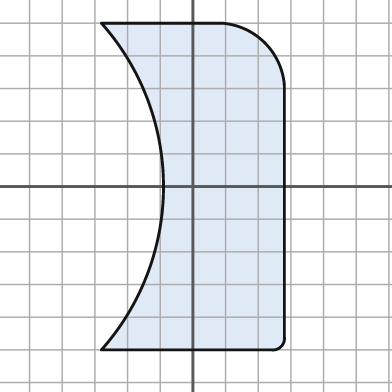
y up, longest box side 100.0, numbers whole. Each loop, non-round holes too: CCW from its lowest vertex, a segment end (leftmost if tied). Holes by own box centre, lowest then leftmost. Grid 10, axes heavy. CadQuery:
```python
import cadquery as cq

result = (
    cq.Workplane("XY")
    .moveTo(-28.0, -50.0)
    .lineTo(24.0, -50.0)
    .threePointArc((27.0, -49.0), (28.0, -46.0))
    .lineTo(28.0, 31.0)
    .threePointArc((22.0, 44.0), (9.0, 50.0))
    .lineTo(-28.0, 50.0)
    .threePointArc((-9.0, 0.0), (-28.0, -50.0))
    .close()
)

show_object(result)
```